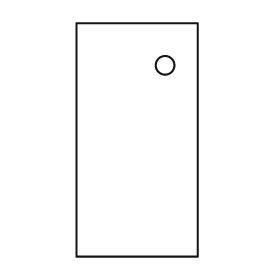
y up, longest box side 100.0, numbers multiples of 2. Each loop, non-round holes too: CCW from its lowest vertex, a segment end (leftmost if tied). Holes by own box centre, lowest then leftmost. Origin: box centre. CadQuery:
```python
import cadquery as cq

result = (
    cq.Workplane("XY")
    .moveTo(-26.0, -50.0)
    .lineTo(26.0, -50.0)
    .lineTo(26.0, 50.0)
    .lineTo(-26.0, 50.0)
    .close()
    .moveTo(12.0, 32.0)
    .circle(4.0)
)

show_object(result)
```